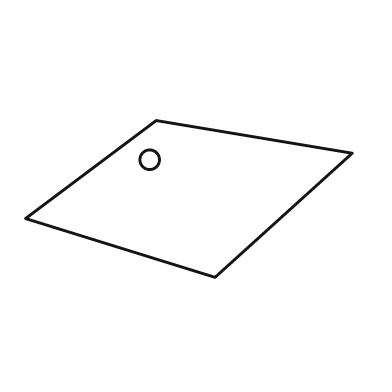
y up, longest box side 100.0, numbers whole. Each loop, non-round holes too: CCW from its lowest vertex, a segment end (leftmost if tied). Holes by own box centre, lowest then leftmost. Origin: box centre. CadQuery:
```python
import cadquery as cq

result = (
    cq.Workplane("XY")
    .moveTo(8.0, -24.0)
    .lineTo(50.0, 14.0)
    .lineTo(-10.0, 24.0)
    .lineTo(-50.0, -6.0)
    .close()
    .moveTo(-12.0, 12.0)
    .circle(3.0)
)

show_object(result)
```